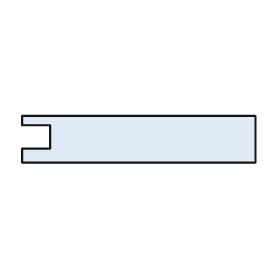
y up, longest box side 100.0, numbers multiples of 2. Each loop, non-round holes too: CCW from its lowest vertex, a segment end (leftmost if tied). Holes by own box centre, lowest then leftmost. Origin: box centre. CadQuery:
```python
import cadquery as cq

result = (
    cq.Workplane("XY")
    .moveTo(-50.0, -10.0)
    .lineTo(50.0, -10.0)
    .lineTo(50.0, 10.0)
    .lineTo(-50.0, 10.0)
    .lineTo(-50.0, 6.0)
    .lineTo(-38.0, 6.0)
    .lineTo(-38.0, -4.0)
    .lineTo(-50.0, -4.0)
    .close()
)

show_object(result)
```